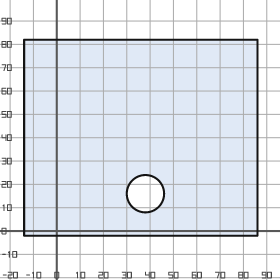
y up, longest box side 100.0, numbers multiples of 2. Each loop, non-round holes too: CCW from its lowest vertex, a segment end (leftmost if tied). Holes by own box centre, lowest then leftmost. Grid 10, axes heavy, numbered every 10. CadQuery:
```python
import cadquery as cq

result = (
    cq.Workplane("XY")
    .moveTo(-14.0, -2.0)
    .lineTo(86.0, -2.0)
    .lineTo(86.0, 82.0)
    .lineTo(-14.0, 82.0)
    .close()
    .moveTo(38.0, 16.0)
    .circle(8.0)
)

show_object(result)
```